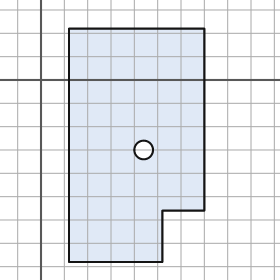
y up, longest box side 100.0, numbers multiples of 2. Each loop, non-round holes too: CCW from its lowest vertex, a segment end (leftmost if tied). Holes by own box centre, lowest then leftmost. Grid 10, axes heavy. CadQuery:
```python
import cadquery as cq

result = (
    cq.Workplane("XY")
    .moveTo(12.0, -78.0)
    .lineTo(52.0, -78.0)
    .lineTo(52.0, -56.0)
    .lineTo(70.0, -56.0)
    .lineTo(70.0, 22.0)
    .lineTo(12.0, 22.0)
    .close()
    .moveTo(44.0, -30.0)
    .circle(4.0)
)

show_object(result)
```